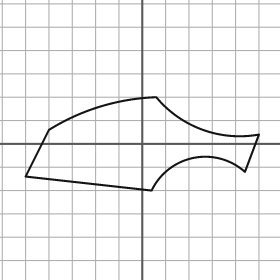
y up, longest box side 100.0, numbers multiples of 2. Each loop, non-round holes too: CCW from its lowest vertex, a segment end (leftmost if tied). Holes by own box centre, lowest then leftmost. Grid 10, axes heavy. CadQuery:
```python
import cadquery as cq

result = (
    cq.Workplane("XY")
    .moveTo(4.0, -20.0)
    .threePointArc((22.0, -6.0), (44.0, -12.0))
    .lineTo(50.0, 4.0)
    .threePointArc((26.0, 6.0), (6.0, 20.0))
    .threePointArc((-18.0, 16.0), (-40.0, 6.0))
    .lineTo(-50.0, -14.0)
    .close()
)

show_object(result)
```